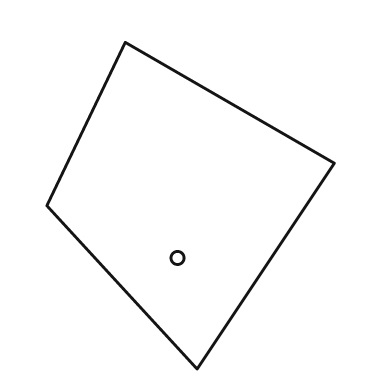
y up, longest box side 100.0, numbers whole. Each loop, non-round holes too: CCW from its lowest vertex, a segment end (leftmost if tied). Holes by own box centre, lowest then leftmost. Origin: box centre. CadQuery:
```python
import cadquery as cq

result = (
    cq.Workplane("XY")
    .moveTo(2.0, -50.0)
    .lineTo(44.0, 13.0)
    .lineTo(-20.0, 50.0)
    .lineTo(-44.0, 0.0)
    .close()
    .moveTo(-4.0, -16.0)
    .circle(2.0)
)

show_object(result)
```